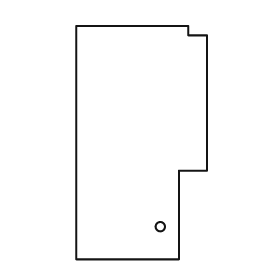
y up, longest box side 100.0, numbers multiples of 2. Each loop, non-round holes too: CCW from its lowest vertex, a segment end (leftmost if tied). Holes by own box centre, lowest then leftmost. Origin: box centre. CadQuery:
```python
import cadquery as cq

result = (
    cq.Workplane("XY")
    .moveTo(-28.0, -50.0)
    .lineTo(16.0, -50.0)
    .lineTo(16.0, -12.0)
    .lineTo(28.0, -12.0)
    .lineTo(28.0, 46.0)
    .lineTo(20.0, 46.0)
    .lineTo(20.0, 50.0)
    .lineTo(-28.0, 50.0)
    .close()
    .moveTo(8.0, -36.0)
    .circle(2.0)
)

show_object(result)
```